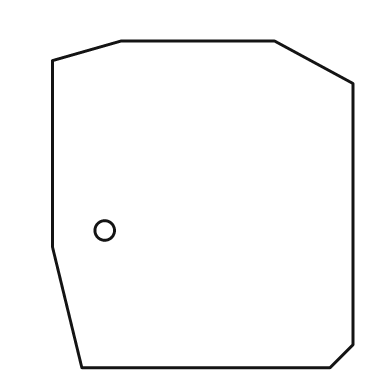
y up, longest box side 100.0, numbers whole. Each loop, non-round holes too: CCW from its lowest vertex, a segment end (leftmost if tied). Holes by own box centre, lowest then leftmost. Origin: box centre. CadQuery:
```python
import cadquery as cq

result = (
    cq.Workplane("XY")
    .moveTo(-37.0, -50.0)
    .lineTo(39.0, -50.0)
    .lineTo(46.0, -43.0)
    .lineTo(46.0, 37.0)
    .lineTo(22.0, 50.0)
    .lineTo(-25.0, 50.0)
    .lineTo(-46.0, 44.0)
    .lineTo(-46.0, -13.0)
    .close()
    .moveTo(-30.0, -8.0)
    .circle(3.0)
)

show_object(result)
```